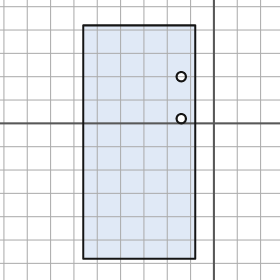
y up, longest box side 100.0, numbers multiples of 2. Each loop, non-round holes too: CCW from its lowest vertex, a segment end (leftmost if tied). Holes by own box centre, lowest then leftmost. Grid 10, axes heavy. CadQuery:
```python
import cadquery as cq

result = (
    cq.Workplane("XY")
    .moveTo(-56.0, -58.0)
    .lineTo(-8.0, -58.0)
    .lineTo(-8.0, 42.0)
    .lineTo(-56.0, 42.0)
    .close()
    .moveTo(-14.0, 2.0)
    .circle(2.0)
    .moveTo(-14.0, 20.0)
    .circle(2.0)
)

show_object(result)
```